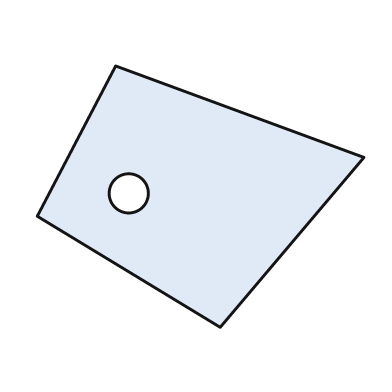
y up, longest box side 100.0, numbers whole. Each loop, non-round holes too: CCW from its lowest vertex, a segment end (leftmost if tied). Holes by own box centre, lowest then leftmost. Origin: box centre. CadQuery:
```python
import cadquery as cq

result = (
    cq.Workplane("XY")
    .moveTo(6.0, -40.0)
    .lineTo(50.0, 12.0)
    .lineTo(-26.0, 40.0)
    .lineTo(-50.0, -6.0)
    .close()
    .moveTo(-22.0, 1.0)
    .circle(6.0)
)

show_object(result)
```